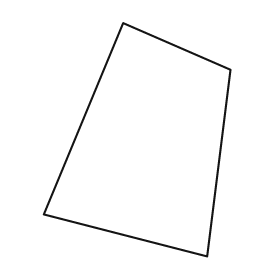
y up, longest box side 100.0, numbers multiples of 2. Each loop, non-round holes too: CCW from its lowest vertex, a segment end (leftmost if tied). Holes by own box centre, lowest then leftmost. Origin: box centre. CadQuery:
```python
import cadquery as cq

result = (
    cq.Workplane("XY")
    .moveTo(30.0, -50.0)
    .lineTo(40.0, 30.0)
    .lineTo(-6.0, 50.0)
    .lineTo(-40.0, -32.0)
    .close()
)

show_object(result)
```